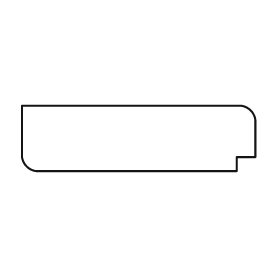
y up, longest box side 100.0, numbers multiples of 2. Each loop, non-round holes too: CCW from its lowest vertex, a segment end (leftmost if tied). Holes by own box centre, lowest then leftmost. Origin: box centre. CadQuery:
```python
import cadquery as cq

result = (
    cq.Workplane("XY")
    .moveTo(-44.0, -14.0)
    .lineTo(42.0, -14.0)
    .lineTo(42.0, -8.0)
    .lineTo(50.0, -8.0)
    .lineTo(50.0, 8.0)
    .threePointArc((48.0, 12.0), (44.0, 14.0))
    .lineTo(-50.0, 14.0)
    .lineTo(-50.0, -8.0)
    .threePointArc((-48.0, -12.0), (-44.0, -14.0))
    .close()
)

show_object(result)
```